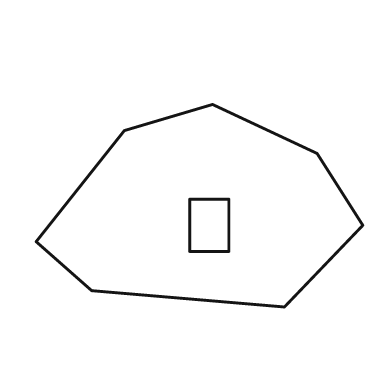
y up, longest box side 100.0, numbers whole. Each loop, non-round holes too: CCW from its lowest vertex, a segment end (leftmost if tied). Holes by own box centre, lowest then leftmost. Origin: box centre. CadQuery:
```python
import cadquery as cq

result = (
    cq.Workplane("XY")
    .moveTo(26.0, -31.0)
    .lineTo(50.0, -6.0)
    .lineTo(36.0, 16.0)
    .lineTo(4.0, 31.0)
    .lineTo(-23.0, 23.0)
    .lineTo(-50.0, -11.0)
    .lineTo(-33.0, -26.0)
    .close()
    .moveTo(-3.0, -14.0)
    .lineTo(9.0, -14.0)
    .lineTo(9.0, 2.0)
    .lineTo(-3.0, 2.0)
    .close()
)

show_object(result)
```